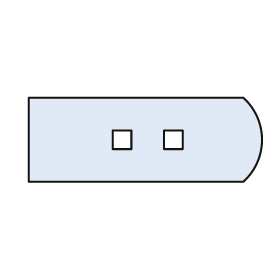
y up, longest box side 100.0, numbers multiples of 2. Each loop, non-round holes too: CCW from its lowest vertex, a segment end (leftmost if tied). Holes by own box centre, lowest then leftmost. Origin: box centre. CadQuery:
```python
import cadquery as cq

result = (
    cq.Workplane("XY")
    .moveTo(-50.0, -18.0)
    .lineTo(42.0, -18.0)
    .threePointArc((50.0, 0.0), (42.0, 18.0))
    .lineTo(-50.0, 18.0)
    .close()
    .moveTo(-14.0, -4.0)
    .lineTo(-6.0, -4.0)
    .lineTo(-6.0, 4.0)
    .lineTo(-14.0, 4.0)
    .close()
    .moveTo(8.0, -4.0)
    .lineTo(16.0, -4.0)
    .lineTo(16.0, 4.0)
    .lineTo(8.0, 4.0)
    .close()
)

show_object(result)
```